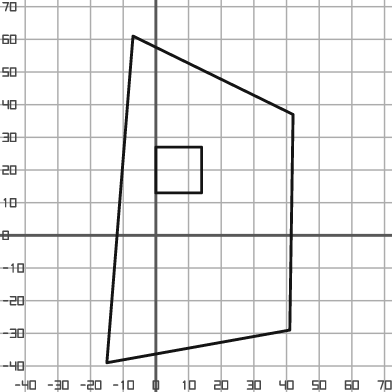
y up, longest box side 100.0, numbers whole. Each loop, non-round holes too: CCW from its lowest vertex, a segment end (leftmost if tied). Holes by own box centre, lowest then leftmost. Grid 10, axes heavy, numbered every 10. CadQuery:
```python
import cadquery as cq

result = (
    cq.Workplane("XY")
    .moveTo(-15.0, -39.0)
    .lineTo(41.0, -29.0)
    .lineTo(42.0, 37.0)
    .lineTo(-7.0, 61.0)
    .close()
    .moveTo(0.0, 13.0)
    .lineTo(14.0, 13.0)
    .lineTo(14.0, 27.0)
    .lineTo(0.0, 27.0)
    .close()
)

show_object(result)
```